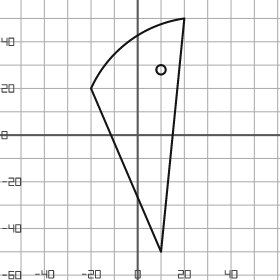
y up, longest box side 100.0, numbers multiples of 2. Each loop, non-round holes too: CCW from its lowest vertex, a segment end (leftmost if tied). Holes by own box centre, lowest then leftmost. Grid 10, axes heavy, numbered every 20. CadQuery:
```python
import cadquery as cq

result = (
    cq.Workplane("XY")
    .moveTo(10.0, -50.0)
    .lineTo(20.0, 50.0)
    .threePointArc((-4.0, 40.0), (-20.0, 20.0))
    .close()
    .moveTo(10.0, 28.0)
    .circle(2.0)
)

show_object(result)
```